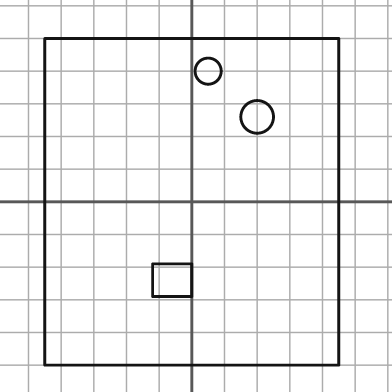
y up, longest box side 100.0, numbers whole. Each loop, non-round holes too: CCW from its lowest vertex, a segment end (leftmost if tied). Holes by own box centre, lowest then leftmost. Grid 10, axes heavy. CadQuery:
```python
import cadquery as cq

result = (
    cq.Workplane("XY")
    .moveTo(-45.0, -50.0)
    .lineTo(45.0, -50.0)
    .lineTo(45.0, 50.0)
    .lineTo(-45.0, 50.0)
    .close()
    .moveTo(-12.0, -29.0)
    .lineTo(0.0, -29.0)
    .lineTo(0.0, -19.0)
    .lineTo(-12.0, -19.0)
    .close()
    .moveTo(20.0, 26.0)
    .circle(5.0)
    .moveTo(5.0, 40.0)
    .circle(4.0)
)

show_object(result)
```